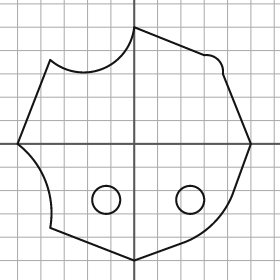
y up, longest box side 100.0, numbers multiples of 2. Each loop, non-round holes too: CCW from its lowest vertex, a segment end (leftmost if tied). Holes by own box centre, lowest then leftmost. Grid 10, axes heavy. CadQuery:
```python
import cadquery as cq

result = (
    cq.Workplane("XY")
    .moveTo(0.0, -50.0)
    .lineTo(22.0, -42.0)
    .threePointArc((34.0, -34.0), (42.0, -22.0))
    .lineTo(50.0, 0.0)
    .lineTo(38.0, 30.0)
    .threePointArc((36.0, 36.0), (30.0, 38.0))
    .lineTo(0.0, 50.0)
    .threePointArc((-14.0, 32.0), (-36.0, 36.0))
    .lineTo(-50.0, 0.0)
    .threePointArc((-38.0, -16.0), (-36.0, -36.0))
    .close()
    .moveTo(-12.0, -24.0)
    .circle(6.0)
    .moveTo(24.0, -24.0)
    .circle(6.0)
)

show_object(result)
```